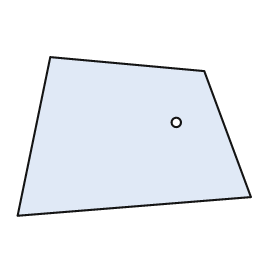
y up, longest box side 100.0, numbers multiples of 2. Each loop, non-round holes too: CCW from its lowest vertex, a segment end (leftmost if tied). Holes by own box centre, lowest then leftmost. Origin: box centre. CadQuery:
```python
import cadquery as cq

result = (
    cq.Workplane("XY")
    .moveTo(-50.0, -34.0)
    .lineTo(50.0, -26.0)
    .lineTo(30.0, 28.0)
    .lineTo(-36.0, 34.0)
    .close()
    .moveTo(18.0, 6.0)
    .circle(2.0)
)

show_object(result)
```